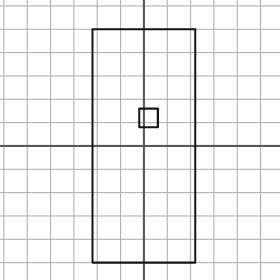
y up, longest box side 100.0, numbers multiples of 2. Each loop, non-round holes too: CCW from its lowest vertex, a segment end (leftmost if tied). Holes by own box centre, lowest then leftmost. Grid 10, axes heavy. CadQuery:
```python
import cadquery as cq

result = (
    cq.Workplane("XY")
    .moveTo(-22.0, -50.0)
    .lineTo(22.0, -50.0)
    .lineTo(22.0, 50.0)
    .lineTo(-22.0, 50.0)
    .close()
    .moveTo(-2.0, 8.0)
    .lineTo(6.0, 8.0)
    .lineTo(6.0, 16.0)
    .lineTo(-2.0, 16.0)
    .close()
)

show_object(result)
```